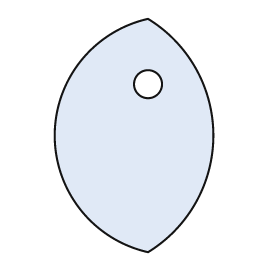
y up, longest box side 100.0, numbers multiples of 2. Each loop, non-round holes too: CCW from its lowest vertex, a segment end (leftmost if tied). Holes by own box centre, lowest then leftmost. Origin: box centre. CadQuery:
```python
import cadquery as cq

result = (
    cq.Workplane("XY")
    .moveTo(6.0, -50.0)
    .threePointArc((34.0, 0.0), (6.0, 50.0))
    .threePointArc((-34.0, 0.0), (6.0, -50.0))
    .close()
    .moveTo(6.0, 22.0)
    .circle(6.0)
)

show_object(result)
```